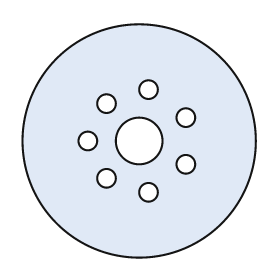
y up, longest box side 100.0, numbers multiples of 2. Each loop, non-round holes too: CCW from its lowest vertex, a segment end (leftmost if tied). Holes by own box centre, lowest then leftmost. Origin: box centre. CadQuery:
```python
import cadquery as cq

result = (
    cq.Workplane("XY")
    .moveTo(0.0, 0.0)
    .circle(50.0)
    .moveTo(4.0, -22.0)
    .circle(4.0)
    .moveTo(-14.0, -16.0)
    .circle(4.0)
    .moveTo(20.0, -10.0)
    .circle(4.0)
    .moveTo(-22.0, 0.0)
    .circle(4.0)
    .moveTo(0.0, 0.0)
    .circle(10.0)
    .moveTo(20.0, 10.0)
    .circle(4.0)
    .moveTo(-14.0, 16.0)
    .circle(4.0)
    .moveTo(4.0, 22.0)
    .circle(4.0)
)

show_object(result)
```